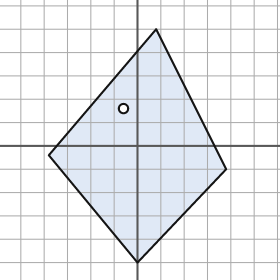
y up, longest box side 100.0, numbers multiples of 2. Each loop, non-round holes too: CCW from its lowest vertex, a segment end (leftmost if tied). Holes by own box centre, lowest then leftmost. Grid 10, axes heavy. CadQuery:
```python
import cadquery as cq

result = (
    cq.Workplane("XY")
    .moveTo(0.0, -50.0)
    .lineTo(38.0, -10.0)
    .lineTo(8.0, 50.0)
    .lineTo(-38.0, -4.0)
    .close()
    .moveTo(-6.0, 16.0)
    .circle(2.0)
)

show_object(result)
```